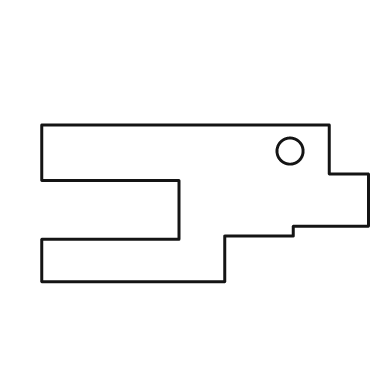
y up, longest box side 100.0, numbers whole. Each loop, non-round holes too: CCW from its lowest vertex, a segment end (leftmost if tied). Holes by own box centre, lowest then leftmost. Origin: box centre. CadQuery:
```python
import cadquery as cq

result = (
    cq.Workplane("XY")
    .moveTo(-50.0, -24.0)
    .lineTo(6.0, -24.0)
    .lineTo(6.0, -10.0)
    .lineTo(27.0, -10.0)
    .lineTo(27.0, -7.0)
    .lineTo(50.0, -7.0)
    .lineTo(50.0, 9.0)
    .lineTo(38.0, 9.0)
    .lineTo(38.0, 24.0)
    .lineTo(-50.0, 24.0)
    .lineTo(-50.0, 7.0)
    .lineTo(-8.0, 7.0)
    .lineTo(-8.0, -11.0)
    .lineTo(-50.0, -11.0)
    .close()
    .moveTo(26.0, 16.0)
    .circle(4.0)
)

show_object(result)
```